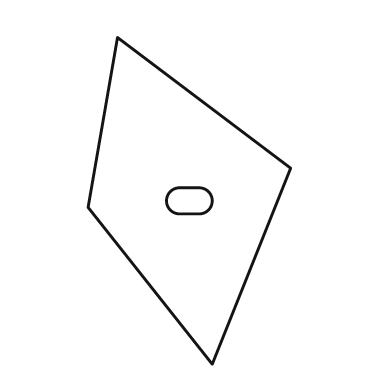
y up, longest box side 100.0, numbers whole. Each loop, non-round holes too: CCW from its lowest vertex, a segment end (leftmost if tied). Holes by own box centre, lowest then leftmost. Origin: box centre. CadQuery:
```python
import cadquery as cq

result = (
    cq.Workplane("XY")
    .moveTo(7.0, -50.0)
    .lineTo(31.0, 10.0)
    .lineTo(-22.0, 50.0)
    .lineTo(-31.0, -2.0)
    .close()
    .moveTo(-3.0, -4.0)
    .lineTo(3.0, -4.0)
    .threePointArc((7.0, 0.0), (3.0, 4.0))
    .lineTo(-3.0, 4.0)
    .threePointArc((-7.0, 0.0), (-3.0, -4.0))
    .close()
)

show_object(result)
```